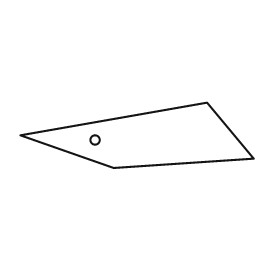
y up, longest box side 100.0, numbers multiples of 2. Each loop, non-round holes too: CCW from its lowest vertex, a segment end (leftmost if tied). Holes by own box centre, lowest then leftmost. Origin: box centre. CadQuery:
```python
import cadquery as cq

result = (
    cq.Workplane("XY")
    .moveTo(-10.0, -14.0)
    .lineTo(50.0, -10.0)
    .lineTo(30.0, 14.0)
    .lineTo(-50.0, 0.0)
    .close()
    .moveTo(-18.0, -2.0)
    .circle(2.0)
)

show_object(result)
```